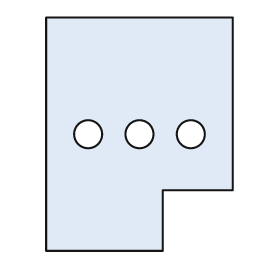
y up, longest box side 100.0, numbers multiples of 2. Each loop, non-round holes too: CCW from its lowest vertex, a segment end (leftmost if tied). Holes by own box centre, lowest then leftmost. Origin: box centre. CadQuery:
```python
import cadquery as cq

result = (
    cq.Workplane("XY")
    .moveTo(-40.0, -50.0)
    .lineTo(10.0, -50.0)
    .lineTo(10.0, -24.0)
    .lineTo(40.0, -24.0)
    .lineTo(40.0, 50.0)
    .lineTo(-40.0, 50.0)
    .close()
    .moveTo(-22.0, 0.0)
    .circle(6.0)
    .moveTo(0.0, 0.0)
    .circle(6.0)
    .moveTo(22.0, 0.0)
    .circle(6.0)
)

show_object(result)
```